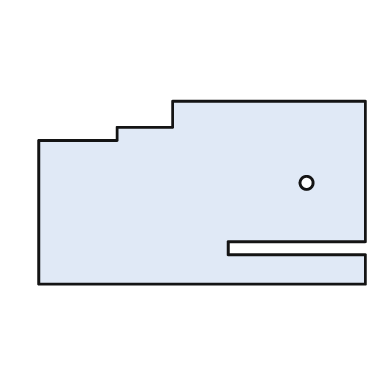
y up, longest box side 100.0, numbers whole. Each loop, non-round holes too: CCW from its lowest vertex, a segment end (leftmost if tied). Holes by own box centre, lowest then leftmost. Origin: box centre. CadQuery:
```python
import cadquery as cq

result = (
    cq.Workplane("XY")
    .moveTo(-50.0, -28.0)
    .lineTo(50.0, -28.0)
    .lineTo(50.0, -19.0)
    .lineTo(8.0, -19.0)
    .lineTo(8.0, -15.0)
    .lineTo(50.0, -15.0)
    .lineTo(50.0, 28.0)
    .lineTo(-9.0, 28.0)
    .lineTo(-9.0, 20.0)
    .lineTo(-26.0, 20.0)
    .lineTo(-26.0, 16.0)
    .lineTo(-50.0, 16.0)
    .close()
    .moveTo(32.0, 3.0)
    .circle(2.0)
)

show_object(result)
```